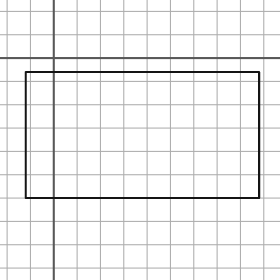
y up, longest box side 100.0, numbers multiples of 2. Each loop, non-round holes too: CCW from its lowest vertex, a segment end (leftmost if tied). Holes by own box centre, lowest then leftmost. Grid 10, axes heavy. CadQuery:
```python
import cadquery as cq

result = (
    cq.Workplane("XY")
    .moveTo(-12.0, -60.0)
    .lineTo(88.0, -60.0)
    .lineTo(88.0, -6.0)
    .lineTo(-12.0, -6.0)
    .close()
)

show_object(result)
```